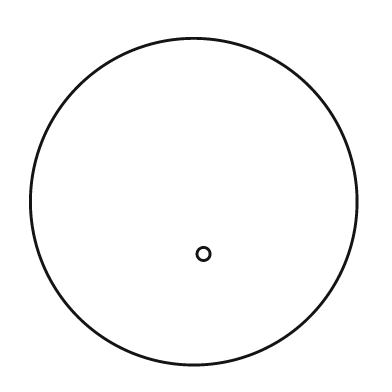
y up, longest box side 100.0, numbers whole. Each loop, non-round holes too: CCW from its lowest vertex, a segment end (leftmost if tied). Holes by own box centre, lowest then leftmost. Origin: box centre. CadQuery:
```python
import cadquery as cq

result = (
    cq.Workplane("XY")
    .moveTo(0.0, 0.0)
    .circle(50.0)
    .moveTo(3.0, -16.0)
    .circle(2.0)
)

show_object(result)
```